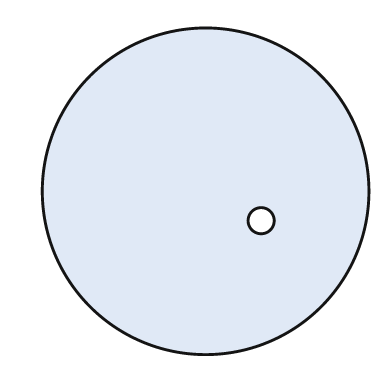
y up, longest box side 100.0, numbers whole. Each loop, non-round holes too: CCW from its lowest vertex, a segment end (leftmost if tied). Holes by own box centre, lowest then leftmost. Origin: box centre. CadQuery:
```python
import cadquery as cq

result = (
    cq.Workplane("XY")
    .moveTo(0.0, 0.0)
    .circle(50.0)
    .moveTo(17.0, -9.0)
    .circle(4.0)
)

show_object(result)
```